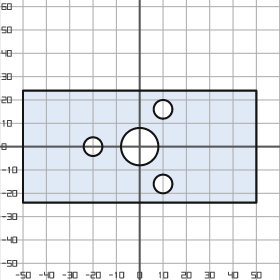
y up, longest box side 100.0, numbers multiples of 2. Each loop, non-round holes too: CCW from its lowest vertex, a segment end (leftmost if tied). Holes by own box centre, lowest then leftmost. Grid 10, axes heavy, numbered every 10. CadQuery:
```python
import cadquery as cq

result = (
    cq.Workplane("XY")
    .moveTo(-50.0, -24.0)
    .lineTo(50.0, -24.0)
    .lineTo(50.0, 24.0)
    .lineTo(-50.0, 24.0)
    .close()
    .moveTo(10.0, -16.0)
    .circle(4.0)
    .moveTo(-20.0, 0.0)
    .circle(4.0)
    .moveTo(0.0, 0.0)
    .circle(8.0)
    .moveTo(10.0, 16.0)
    .circle(4.0)
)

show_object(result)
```